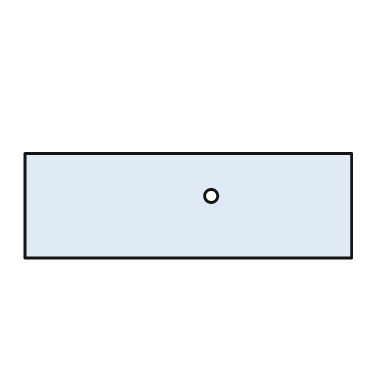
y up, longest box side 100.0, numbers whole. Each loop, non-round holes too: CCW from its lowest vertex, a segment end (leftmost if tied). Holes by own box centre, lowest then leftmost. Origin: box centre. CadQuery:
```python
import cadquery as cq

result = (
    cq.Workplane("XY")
    .moveTo(-50.0, -16.0)
    .lineTo(50.0, -16.0)
    .lineTo(50.0, 16.0)
    .lineTo(-50.0, 16.0)
    .close()
    .moveTo(7.0, 3.0)
    .circle(2.0)
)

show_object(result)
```